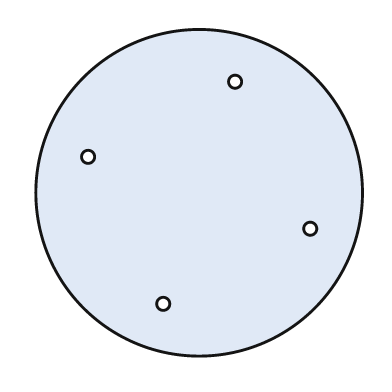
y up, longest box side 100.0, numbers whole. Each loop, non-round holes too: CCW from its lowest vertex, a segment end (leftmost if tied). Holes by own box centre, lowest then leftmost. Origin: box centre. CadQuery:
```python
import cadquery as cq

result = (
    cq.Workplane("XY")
    .moveTo(0.0, 0.0)
    .circle(50.0)
    .moveTo(-11.0, -34.0)
    .circle(2.0)
    .moveTo(34.0, -11.0)
    .circle(2.0)
    .moveTo(-34.0, 11.0)
    .circle(2.0)
    .moveTo(11.0, 34.0)
    .circle(2.0)
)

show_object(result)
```